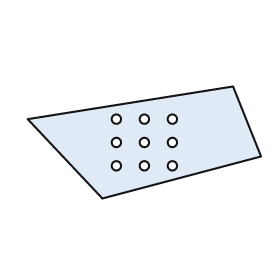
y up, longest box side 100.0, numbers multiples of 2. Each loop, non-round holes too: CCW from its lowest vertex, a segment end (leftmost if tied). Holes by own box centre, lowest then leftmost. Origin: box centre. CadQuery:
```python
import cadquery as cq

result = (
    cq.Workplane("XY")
    .moveTo(-18.0, -24.0)
    .lineTo(50.0, -6.0)
    .lineTo(38.0, 24.0)
    .lineTo(-50.0, 10.0)
    .close()
    .moveTo(-12.0, -10.0)
    .circle(2.0)
    .moveTo(0.0, -10.0)
    .circle(2.0)
    .moveTo(12.0, -10.0)
    .circle(2.0)
    .moveTo(-12.0, 0.0)
    .circle(2.0)
    .moveTo(0.0, 0.0)
    .circle(2.0)
    .moveTo(12.0, 0.0)
    .circle(2.0)
    .moveTo(-12.0, 10.0)
    .circle(2.0)
    .moveTo(0.0, 10.0)
    .circle(2.0)
    .moveTo(12.0, 10.0)
    .circle(2.0)
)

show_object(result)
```